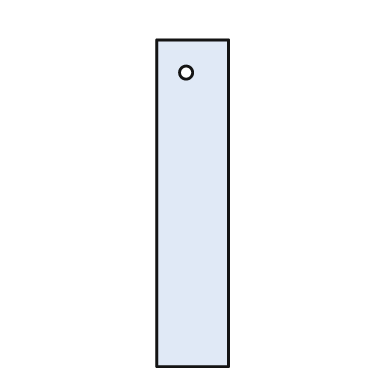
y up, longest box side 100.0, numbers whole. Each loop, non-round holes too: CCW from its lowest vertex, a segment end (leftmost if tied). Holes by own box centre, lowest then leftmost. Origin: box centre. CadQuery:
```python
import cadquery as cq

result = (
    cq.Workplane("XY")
    .moveTo(-11.0, -50.0)
    .lineTo(11.0, -50.0)
    .lineTo(11.0, 50.0)
    .lineTo(-11.0, 50.0)
    .close()
    .moveTo(-2.0, 40.0)
    .circle(2.0)
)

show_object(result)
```